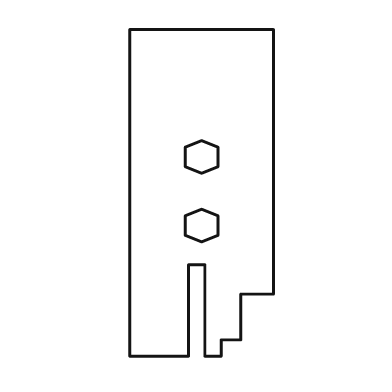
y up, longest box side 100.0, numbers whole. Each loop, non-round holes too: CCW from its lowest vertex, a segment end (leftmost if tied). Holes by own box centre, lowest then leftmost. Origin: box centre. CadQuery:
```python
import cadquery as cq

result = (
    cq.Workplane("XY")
    .moveTo(-22.0, -50.0)
    .lineTo(-4.0, -50.0)
    .lineTo(-4.0, -22.0)
    .lineTo(1.0, -22.0)
    .lineTo(1.0, -50.0)
    .lineTo(6.0, -50.0)
    .lineTo(6.0, -45.0)
    .lineTo(12.0, -45.0)
    .lineTo(12.0, -31.0)
    .lineTo(22.0, -31.0)
    .lineTo(22.0, 50.0)
    .lineTo(-22.0, 50.0)
    .close()
    .moveTo(0.0, -15.0)
    .lineTo(5.0, -13.0)
    .lineTo(5.0, -7.0)
    .lineTo(0.0, -5.0)
    .lineTo(-5.0, -7.0)
    .lineTo(-5.0, -13.0)
    .close()
    .moveTo(0.0, 6.0)
    .lineTo(5.0, 8.0)
    .lineTo(5.0, 14.0)
    .lineTo(0.0, 16.0)
    .lineTo(-5.0, 14.0)
    .lineTo(-5.0, 8.0)
    .close()
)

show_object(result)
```